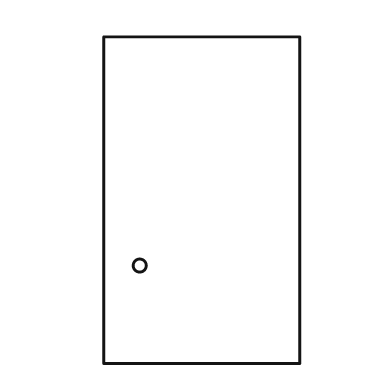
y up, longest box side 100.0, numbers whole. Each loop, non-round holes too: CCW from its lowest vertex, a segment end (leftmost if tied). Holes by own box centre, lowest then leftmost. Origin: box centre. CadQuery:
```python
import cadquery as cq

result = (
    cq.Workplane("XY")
    .moveTo(-30.0, -50.0)
    .lineTo(30.0, -50.0)
    .lineTo(30.0, 50.0)
    .lineTo(-30.0, 50.0)
    .close()
    .moveTo(-19.0, -20.0)
    .circle(2.0)
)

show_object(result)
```